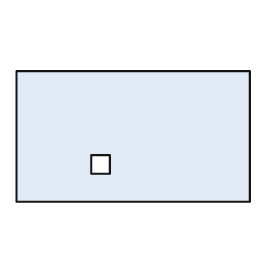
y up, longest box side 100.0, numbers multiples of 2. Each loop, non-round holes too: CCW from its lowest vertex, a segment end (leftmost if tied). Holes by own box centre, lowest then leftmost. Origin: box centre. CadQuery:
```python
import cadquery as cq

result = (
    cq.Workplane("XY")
    .moveTo(-50.0, -28.0)
    .lineTo(50.0, -28.0)
    .lineTo(50.0, 28.0)
    .lineTo(-50.0, 28.0)
    .close()
    .moveTo(-18.0, -16.0)
    .lineTo(-10.0, -16.0)
    .lineTo(-10.0, -8.0)
    .lineTo(-18.0, -8.0)
    .close()
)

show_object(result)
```